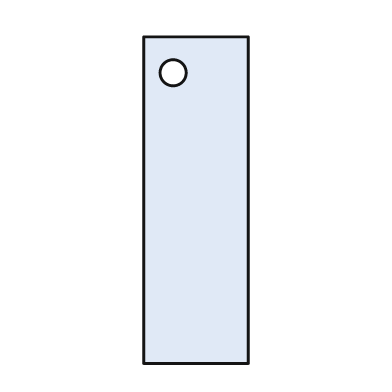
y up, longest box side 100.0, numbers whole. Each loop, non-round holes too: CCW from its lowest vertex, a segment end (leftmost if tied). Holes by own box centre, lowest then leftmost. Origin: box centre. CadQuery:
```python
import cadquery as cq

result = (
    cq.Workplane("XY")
    .moveTo(-16.0, -50.0)
    .lineTo(16.0, -50.0)
    .lineTo(16.0, 50.0)
    .lineTo(-16.0, 50.0)
    .close()
    .moveTo(-7.0, 39.0)
    .circle(4.0)
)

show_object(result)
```